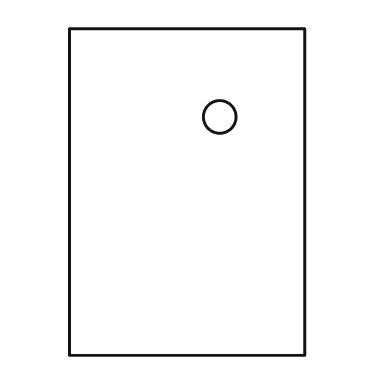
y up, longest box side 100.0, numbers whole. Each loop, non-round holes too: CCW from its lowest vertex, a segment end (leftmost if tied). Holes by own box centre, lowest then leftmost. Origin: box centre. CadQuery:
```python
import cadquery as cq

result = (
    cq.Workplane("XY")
    .moveTo(-36.0, -50.0)
    .lineTo(36.0, -50.0)
    .lineTo(36.0, 50.0)
    .lineTo(-36.0, 50.0)
    .close()
    .moveTo(10.0, 23.0)
    .circle(5.0)
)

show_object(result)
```